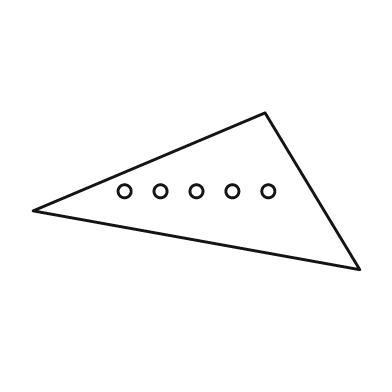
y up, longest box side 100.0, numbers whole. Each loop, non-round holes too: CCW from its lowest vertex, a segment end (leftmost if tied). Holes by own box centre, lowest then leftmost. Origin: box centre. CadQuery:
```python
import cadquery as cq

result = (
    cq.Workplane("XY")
    .moveTo(50.0, -24.0)
    .lineTo(21.0, 24.0)
    .lineTo(-50.0, -6.0)
    .close()
    .moveTo(-22.0, 0.0)
    .circle(2.0)
    .moveTo(-11.0, 0.0)
    .circle(2.0)
    .moveTo(0.0, 0.0)
    .circle(2.0)
    .moveTo(11.0, 0.0)
    .circle(2.0)
    .moveTo(22.0, 0.0)
    .circle(2.0)
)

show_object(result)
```